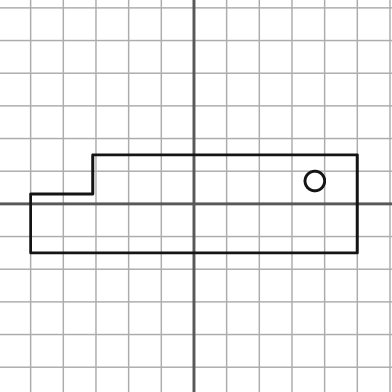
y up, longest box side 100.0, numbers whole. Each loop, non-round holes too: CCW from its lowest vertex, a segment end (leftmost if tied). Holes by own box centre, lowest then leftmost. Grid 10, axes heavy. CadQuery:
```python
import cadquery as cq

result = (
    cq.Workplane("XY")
    .moveTo(-50.0, -15.0)
    .lineTo(50.0, -15.0)
    .lineTo(50.0, 15.0)
    .lineTo(-31.0, 15.0)
    .lineTo(-31.0, 3.0)
    .lineTo(-50.0, 3.0)
    .close()
    .moveTo(37.0, 7.0)
    .circle(3.0)
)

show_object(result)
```